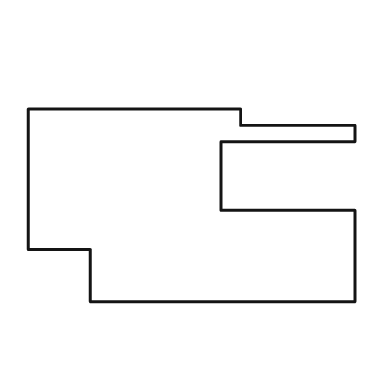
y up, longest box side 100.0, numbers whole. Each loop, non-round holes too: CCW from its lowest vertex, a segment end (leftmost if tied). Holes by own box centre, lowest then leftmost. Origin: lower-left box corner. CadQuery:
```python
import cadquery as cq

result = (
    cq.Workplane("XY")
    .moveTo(19.0, 0.0)
    .lineTo(100.0, 0.0)
    .lineTo(100.0, 28.0)
    .lineTo(59.0, 28.0)
    .lineTo(59.0, 49.0)
    .lineTo(100.0, 49.0)
    .lineTo(100.0, 54.0)
    .lineTo(65.0, 54.0)
    .lineTo(65.0, 59.0)
    .lineTo(0.0, 59.0)
    .lineTo(0.0, 16.0)
    .lineTo(19.0, 16.0)
    .close()
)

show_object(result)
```